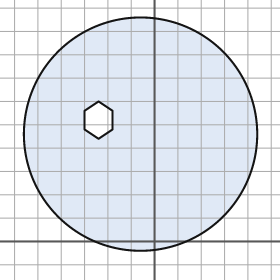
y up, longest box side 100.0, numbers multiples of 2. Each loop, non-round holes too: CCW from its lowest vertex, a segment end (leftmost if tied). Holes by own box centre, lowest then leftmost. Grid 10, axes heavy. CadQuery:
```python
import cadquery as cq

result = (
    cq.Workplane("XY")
    .moveTo(-6.0, 46.0)
    .circle(50.0)
    .moveTo(-24.0, 44.0)
    .lineTo(-18.0, 48.0)
    .lineTo(-18.0, 56.0)
    .lineTo(-24.0, 60.0)
    .lineTo(-30.0, 56.0)
    .lineTo(-30.0, 48.0)
    .close()
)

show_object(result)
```